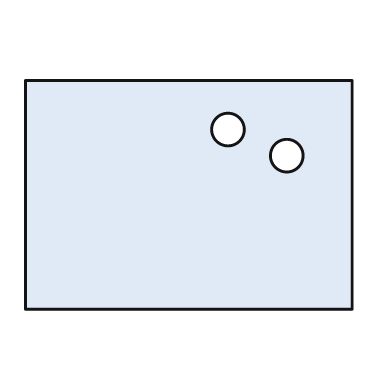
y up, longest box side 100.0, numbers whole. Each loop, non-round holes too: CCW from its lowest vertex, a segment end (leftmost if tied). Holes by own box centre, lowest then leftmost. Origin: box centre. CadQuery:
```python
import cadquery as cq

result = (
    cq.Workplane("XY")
    .moveTo(-50.0, -35.0)
    .lineTo(50.0, -35.0)
    .lineTo(50.0, 35.0)
    .lineTo(-50.0, 35.0)
    .close()
    .moveTo(30.0, 12.0)
    .circle(5.0)
    .moveTo(12.0, 20.0)
    .circle(5.0)
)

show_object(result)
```